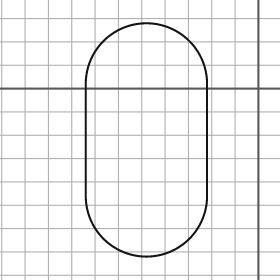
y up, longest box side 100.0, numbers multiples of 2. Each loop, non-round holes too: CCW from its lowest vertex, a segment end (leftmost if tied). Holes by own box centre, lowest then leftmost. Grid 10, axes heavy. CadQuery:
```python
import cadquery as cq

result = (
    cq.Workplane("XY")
    .moveTo(-74.0, -46.0)
    .threePointArc((-48.0, -72.0), (-22.0, -46.0))
    .lineTo(-22.0, 2.0)
    .threePointArc((-48.0, 28.0), (-74.0, 2.0))
    .close()
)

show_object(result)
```